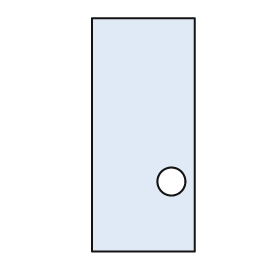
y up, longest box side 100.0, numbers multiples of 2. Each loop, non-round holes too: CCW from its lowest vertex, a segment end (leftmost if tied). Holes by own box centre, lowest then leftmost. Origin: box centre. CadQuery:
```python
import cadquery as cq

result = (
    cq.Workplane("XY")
    .moveTo(-22.0, -50.0)
    .lineTo(22.0, -50.0)
    .lineTo(22.0, 50.0)
    .lineTo(-22.0, 50.0)
    .close()
    .moveTo(12.0, -20.0)
    .circle(6.0)
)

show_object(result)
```